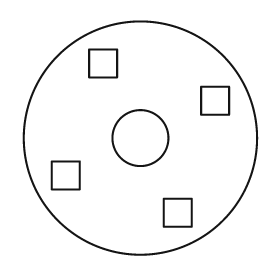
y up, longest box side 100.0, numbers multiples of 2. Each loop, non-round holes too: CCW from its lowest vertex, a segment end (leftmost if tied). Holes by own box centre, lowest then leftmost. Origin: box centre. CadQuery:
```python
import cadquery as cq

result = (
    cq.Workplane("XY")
    .moveTo(0.0, 0.0)
    .circle(50.0)
    .moveTo(10.0, -38.0)
    .lineTo(22.0, -38.0)
    .lineTo(22.0, -26.0)
    .lineTo(10.0, -26.0)
    .close()
    .moveTo(-38.0, -22.0)
    .lineTo(-26.0, -22.0)
    .lineTo(-26.0, -10.0)
    .lineTo(-38.0, -10.0)
    .close()
    .moveTo(0.0, 0.0)
    .circle(12.0)
    .moveTo(26.0, 10.0)
    .lineTo(38.0, 10.0)
    .lineTo(38.0, 22.0)
    .lineTo(26.0, 22.0)
    .close()
    .moveTo(-22.0, 26.0)
    .lineTo(-10.0, 26.0)
    .lineTo(-10.0, 38.0)
    .lineTo(-22.0, 38.0)
    .close()
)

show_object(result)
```